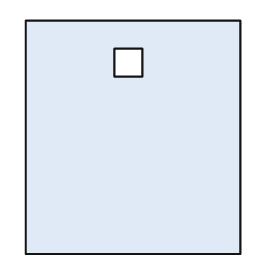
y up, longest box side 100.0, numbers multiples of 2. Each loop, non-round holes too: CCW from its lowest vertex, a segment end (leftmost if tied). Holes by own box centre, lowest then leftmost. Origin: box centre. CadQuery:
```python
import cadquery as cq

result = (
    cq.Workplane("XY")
    .moveTo(-46.0, -50.0)
    .lineTo(46.0, -50.0)
    .lineTo(46.0, 50.0)
    .lineTo(-46.0, 50.0)
    .close()
    .moveTo(-8.0, 26.0)
    .lineTo(4.0, 26.0)
    .lineTo(4.0, 38.0)
    .lineTo(-8.0, 38.0)
    .close()
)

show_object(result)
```